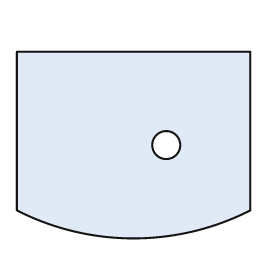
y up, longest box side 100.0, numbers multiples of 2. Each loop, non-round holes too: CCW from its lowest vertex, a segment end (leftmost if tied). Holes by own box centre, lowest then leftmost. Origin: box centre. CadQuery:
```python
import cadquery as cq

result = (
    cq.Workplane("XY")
    .moveTo(-50.0, -28.0)
    .threePointArc((0.0, -40.0), (50.0, -28.0))
    .lineTo(50.0, 40.0)
    .lineTo(-50.0, 40.0)
    .close()
    .moveTo(14.0, 0.0)
    .circle(6.0)
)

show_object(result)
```